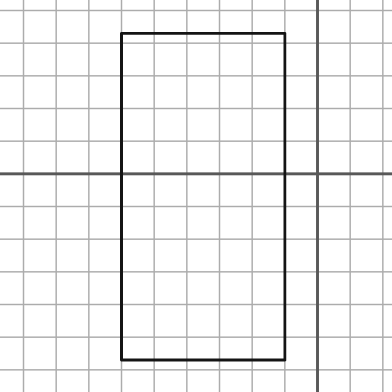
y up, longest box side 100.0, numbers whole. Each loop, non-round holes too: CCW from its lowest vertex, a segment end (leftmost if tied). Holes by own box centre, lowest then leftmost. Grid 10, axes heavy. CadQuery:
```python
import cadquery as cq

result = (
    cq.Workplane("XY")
    .moveTo(-60.0, -57.0)
    .lineTo(-10.0, -57.0)
    .lineTo(-10.0, 43.0)
    .lineTo(-60.0, 43.0)
    .close()
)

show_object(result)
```